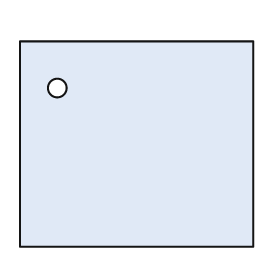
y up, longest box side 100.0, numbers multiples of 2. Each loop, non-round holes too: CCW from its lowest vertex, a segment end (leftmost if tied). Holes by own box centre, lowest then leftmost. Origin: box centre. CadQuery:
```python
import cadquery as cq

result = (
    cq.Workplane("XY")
    .moveTo(-50.0, -44.0)
    .lineTo(50.0, -44.0)
    .lineTo(50.0, 44.0)
    .lineTo(-50.0, 44.0)
    .close()
    .moveTo(-34.0, 24.0)
    .circle(4.0)
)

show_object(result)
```